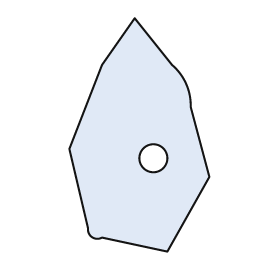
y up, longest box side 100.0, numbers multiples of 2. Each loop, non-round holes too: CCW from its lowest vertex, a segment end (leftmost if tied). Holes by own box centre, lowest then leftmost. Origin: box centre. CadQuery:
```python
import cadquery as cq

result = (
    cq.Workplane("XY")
    .moveTo(12.0, -50.0)
    .lineTo(30.0, -18.0)
    .lineTo(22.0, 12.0)
    .threePointArc((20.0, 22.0), (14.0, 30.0))
    .lineTo(-2.0, 50.0)
    .lineTo(-16.0, 30.0)
    .lineTo(-30.0, -6.0)
    .lineTo(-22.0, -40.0)
    .threePointArc((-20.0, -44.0), (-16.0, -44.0))
    .close()
    .moveTo(6.0, -10.0)
    .circle(6.0)
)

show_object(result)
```